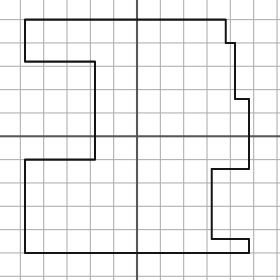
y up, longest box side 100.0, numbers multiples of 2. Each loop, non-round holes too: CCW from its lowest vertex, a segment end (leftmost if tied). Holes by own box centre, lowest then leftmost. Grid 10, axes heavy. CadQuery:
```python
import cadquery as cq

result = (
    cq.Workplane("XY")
    .moveTo(-48.0, -50.0)
    .lineTo(48.0, -50.0)
    .lineTo(48.0, -44.0)
    .lineTo(32.0, -44.0)
    .lineTo(32.0, -14.0)
    .lineTo(48.0, -14.0)
    .lineTo(48.0, 16.0)
    .lineTo(42.0, 16.0)
    .lineTo(42.0, 40.0)
    .lineTo(38.0, 40.0)
    .lineTo(38.0, 50.0)
    .lineTo(-48.0, 50.0)
    .lineTo(-48.0, 32.0)
    .lineTo(-18.0, 32.0)
    .lineTo(-18.0, -10.0)
    .lineTo(-48.0, -10.0)
    .close()
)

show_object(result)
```